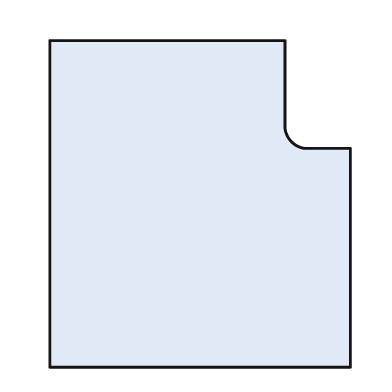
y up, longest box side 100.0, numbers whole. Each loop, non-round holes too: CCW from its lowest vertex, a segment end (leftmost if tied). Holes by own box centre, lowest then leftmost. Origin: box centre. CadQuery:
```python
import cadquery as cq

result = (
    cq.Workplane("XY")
    .moveTo(-46.0, -50.0)
    .lineTo(46.0, -50.0)
    .lineTo(46.0, 17.0)
    .lineTo(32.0, 17.0)
    .threePointArc((28.0, 19.0), (26.0, 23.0))
    .lineTo(26.0, 50.0)
    .lineTo(-46.0, 50.0)
    .close()
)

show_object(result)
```